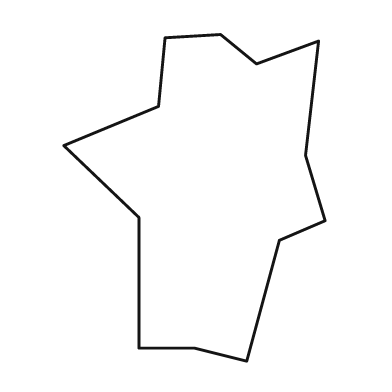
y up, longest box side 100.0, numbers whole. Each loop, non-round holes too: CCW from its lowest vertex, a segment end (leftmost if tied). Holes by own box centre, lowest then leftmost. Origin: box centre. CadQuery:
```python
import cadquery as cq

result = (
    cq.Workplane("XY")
    .moveTo(16.0, -50.0)
    .lineTo(26.0, -13.0)
    .lineTo(40.0, -7.0)
    .lineTo(34.0, 13.0)
    .lineTo(38.0, 48.0)
    .lineTo(19.0, 41.0)
    .lineTo(8.0, 50.0)
    .lineTo(-9.0, 49.0)
    .lineTo(-11.0, 28.0)
    .lineTo(-40.0, 16.0)
    .lineTo(-17.0, -6.0)
    .lineTo(-17.0, -46.0)
    .lineTo(0.0, -46.0)
    .close()
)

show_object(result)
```